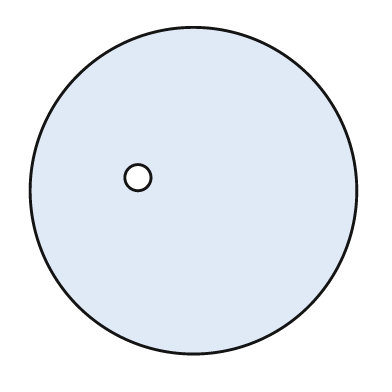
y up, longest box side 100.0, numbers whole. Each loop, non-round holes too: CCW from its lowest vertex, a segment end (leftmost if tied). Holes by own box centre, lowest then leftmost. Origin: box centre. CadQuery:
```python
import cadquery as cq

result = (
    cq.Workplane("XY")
    .moveTo(0.0, 0.0)
    .circle(50.0)
    .moveTo(-17.0, 4.0)
    .circle(4.0)
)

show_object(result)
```